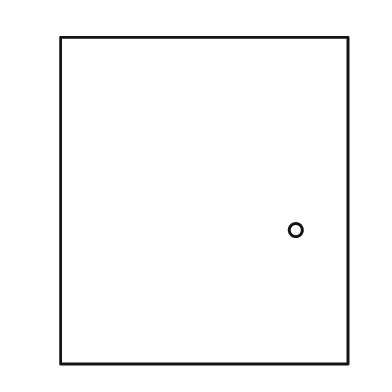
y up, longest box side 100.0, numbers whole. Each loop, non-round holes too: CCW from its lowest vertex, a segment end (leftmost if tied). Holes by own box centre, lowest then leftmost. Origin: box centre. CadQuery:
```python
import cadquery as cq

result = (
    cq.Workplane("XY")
    .moveTo(-44.0, -50.0)
    .lineTo(44.0, -50.0)
    .lineTo(44.0, 50.0)
    .lineTo(-44.0, 50.0)
    .close()
    .moveTo(28.0, -9.0)
    .circle(2.0)
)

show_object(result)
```